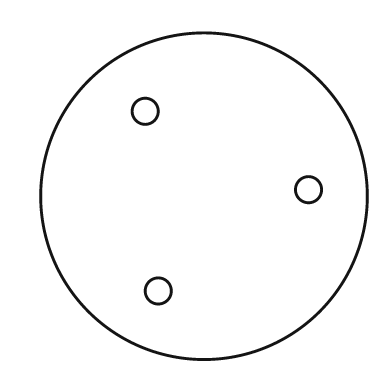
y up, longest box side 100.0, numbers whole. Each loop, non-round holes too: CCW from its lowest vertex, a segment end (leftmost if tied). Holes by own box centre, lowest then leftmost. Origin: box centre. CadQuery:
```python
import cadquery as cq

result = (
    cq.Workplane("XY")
    .moveTo(0.0, 0.0)
    .circle(50.0)
    .moveTo(-14.0, -29.0)
    .circle(4.0)
    .moveTo(32.0, 2.0)
    .circle(4.0)
    .moveTo(-18.0, 26.0)
    .circle(4.0)
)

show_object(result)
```